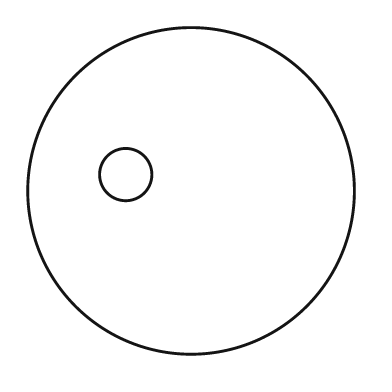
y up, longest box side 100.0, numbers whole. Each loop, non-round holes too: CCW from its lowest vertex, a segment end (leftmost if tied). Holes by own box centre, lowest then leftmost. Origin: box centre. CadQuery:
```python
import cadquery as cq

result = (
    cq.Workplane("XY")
    .moveTo(0.0, 0.0)
    .circle(50.0)
    .moveTo(-20.0, 5.0)
    .circle(8.0)
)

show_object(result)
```